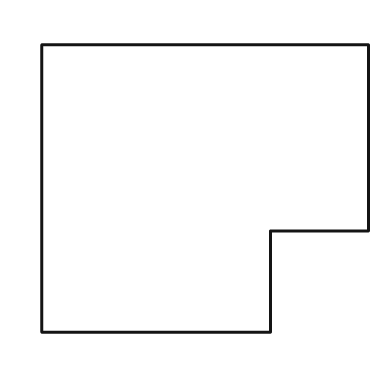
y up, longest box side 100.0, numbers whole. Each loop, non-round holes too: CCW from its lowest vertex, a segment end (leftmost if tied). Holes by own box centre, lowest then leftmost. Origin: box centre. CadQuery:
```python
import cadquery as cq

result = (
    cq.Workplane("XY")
    .moveTo(-50.0, -44.0)
    .lineTo(20.0, -44.0)
    .lineTo(20.0, -13.0)
    .lineTo(50.0, -13.0)
    .lineTo(50.0, 44.0)
    .lineTo(-50.0, 44.0)
    .close()
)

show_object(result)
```